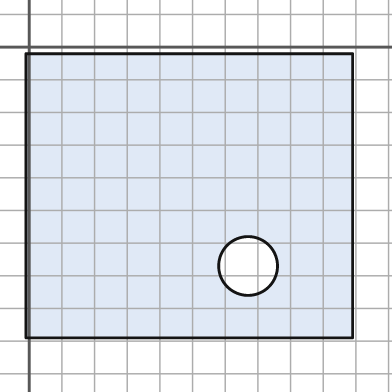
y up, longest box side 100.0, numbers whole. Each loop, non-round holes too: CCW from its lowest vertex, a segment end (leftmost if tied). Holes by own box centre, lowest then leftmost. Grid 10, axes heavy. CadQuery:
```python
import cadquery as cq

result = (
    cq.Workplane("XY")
    .moveTo(-1.0, -89.0)
    .lineTo(99.0, -89.0)
    .lineTo(99.0, -2.0)
    .lineTo(-1.0, -2.0)
    .close()
    .moveTo(67.0, -67.0)
    .circle(9.0)
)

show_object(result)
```